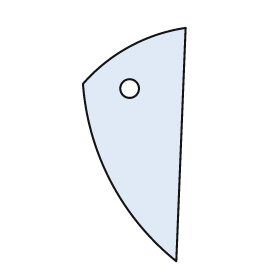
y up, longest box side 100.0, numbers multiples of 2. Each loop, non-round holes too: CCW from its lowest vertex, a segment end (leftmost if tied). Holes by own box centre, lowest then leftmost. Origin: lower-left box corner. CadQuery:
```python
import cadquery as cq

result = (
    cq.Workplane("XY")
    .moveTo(40.0, 0.0)
    .lineTo(44.0, 100.0)
    .threePointArc((20.0, 92.0), (0.0, 76.0))
    .threePointArc((12.0, 34.0), (40.0, 0.0))
    .close()
    .moveTo(20.0, 74.0)
    .circle(4.0)
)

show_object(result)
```